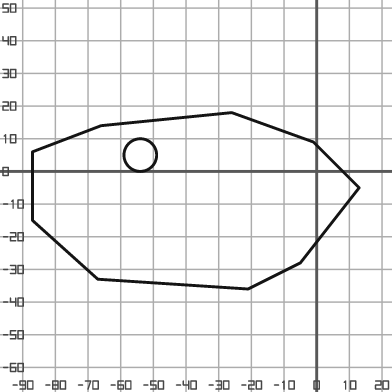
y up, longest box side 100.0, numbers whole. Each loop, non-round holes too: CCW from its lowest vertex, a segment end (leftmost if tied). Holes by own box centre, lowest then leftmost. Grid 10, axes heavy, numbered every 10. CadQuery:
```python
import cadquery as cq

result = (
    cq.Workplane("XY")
    .moveTo(-21.0, -36.0)
    .lineTo(-5.0, -28.0)
    .lineTo(13.0, -5.0)
    .lineTo(-1.0, 9.0)
    .lineTo(-26.0, 18.0)
    .lineTo(-66.0, 14.0)
    .lineTo(-87.0, 6.0)
    .lineTo(-87.0, -15.0)
    .lineTo(-67.0, -33.0)
    .close()
    .moveTo(-54.0, 5.0)
    .circle(5.0)
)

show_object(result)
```